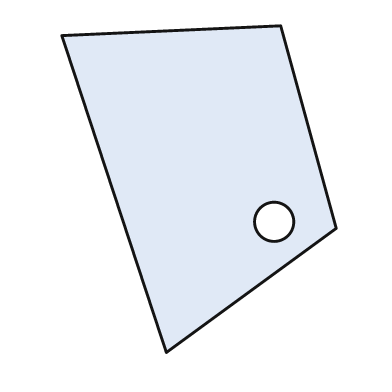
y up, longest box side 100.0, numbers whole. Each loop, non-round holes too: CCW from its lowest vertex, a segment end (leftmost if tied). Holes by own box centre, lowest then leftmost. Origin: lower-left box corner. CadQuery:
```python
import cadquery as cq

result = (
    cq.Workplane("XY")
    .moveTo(32.0, 0.0)
    .lineTo(84.0, 38.0)
    .lineTo(67.0, 100.0)
    .lineTo(0.0, 97.0)
    .close()
    .moveTo(65.0, 40.0)
    .circle(6.0)
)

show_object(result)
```